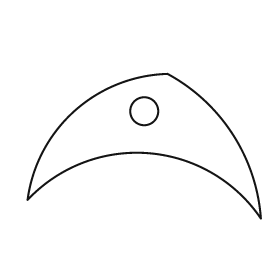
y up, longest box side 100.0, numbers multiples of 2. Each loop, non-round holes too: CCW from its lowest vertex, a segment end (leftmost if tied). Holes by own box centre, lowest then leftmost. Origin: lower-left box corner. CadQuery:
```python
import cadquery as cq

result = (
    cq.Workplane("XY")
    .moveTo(100.0, 0.0)
    .threePointArc((88.0, 36.0), (60.0, 62.0))
    .threePointArc((20.0, 46.0), (0.0, 8.0))
    .threePointArc((52.0, 28.0), (100.0, 0.0))
    .close()
    .moveTo(50.0, 46.0)
    .circle(6.0)
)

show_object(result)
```